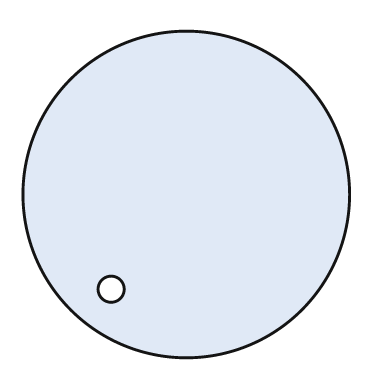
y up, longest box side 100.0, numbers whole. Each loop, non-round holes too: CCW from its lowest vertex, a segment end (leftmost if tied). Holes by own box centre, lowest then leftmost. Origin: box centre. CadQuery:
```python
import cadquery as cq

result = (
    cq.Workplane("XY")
    .moveTo(0.0, 0.0)
    .circle(50.0)
    .moveTo(-23.0, -29.0)
    .circle(4.0)
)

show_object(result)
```